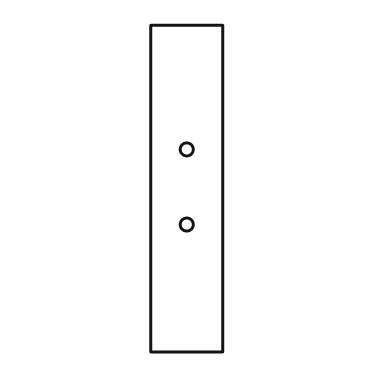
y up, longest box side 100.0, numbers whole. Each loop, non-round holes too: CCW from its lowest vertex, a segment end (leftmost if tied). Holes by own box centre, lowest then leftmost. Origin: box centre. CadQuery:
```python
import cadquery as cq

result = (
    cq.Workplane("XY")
    .moveTo(-11.0, -50.0)
    .lineTo(11.0, -50.0)
    .lineTo(11.0, 50.0)
    .lineTo(-11.0, 50.0)
    .close()
    .moveTo(0.0, -11.0)
    .circle(2.0)
    .moveTo(0.0, 12.0)
    .circle(2.0)
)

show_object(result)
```